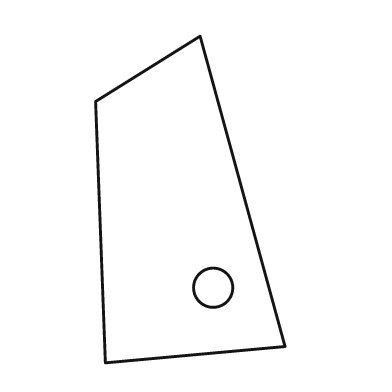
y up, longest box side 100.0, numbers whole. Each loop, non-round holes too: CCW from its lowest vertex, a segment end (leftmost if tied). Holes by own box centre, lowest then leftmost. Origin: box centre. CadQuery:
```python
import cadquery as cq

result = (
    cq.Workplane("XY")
    .moveTo(-26.0, -50.0)
    .lineTo(29.0, -45.0)
    .lineTo(3.0, 50.0)
    .lineTo(-29.0, 30.0)
    .close()
    .moveTo(7.0, -27.0)
    .circle(6.0)
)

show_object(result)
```